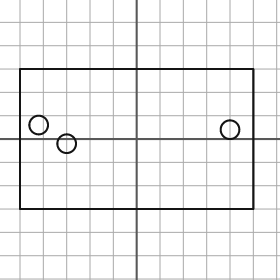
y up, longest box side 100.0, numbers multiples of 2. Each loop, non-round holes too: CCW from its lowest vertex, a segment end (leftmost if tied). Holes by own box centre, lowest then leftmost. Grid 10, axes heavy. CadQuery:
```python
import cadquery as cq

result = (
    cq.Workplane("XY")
    .moveTo(-50.0, -30.0)
    .lineTo(50.0, -30.0)
    .lineTo(50.0, 30.0)
    .lineTo(-50.0, 30.0)
    .close()
    .moveTo(-30.0, -2.0)
    .circle(4.0)
    .moveTo(40.0, 4.0)
    .circle(4.0)
    .moveTo(-42.0, 6.0)
    .circle(4.0)
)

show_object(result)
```